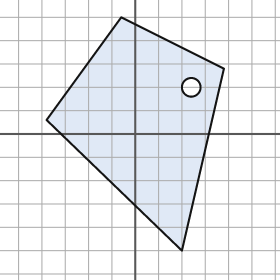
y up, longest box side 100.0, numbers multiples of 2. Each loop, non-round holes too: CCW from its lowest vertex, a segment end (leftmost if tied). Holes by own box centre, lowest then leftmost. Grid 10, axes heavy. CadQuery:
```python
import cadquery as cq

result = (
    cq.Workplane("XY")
    .moveTo(20.0, -50.0)
    .lineTo(38.0, 28.0)
    .lineTo(-6.0, 50.0)
    .lineTo(-38.0, 6.0)
    .close()
    .moveTo(24.0, 20.0)
    .circle(4.0)
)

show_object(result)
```